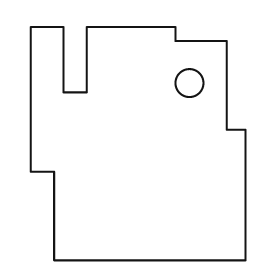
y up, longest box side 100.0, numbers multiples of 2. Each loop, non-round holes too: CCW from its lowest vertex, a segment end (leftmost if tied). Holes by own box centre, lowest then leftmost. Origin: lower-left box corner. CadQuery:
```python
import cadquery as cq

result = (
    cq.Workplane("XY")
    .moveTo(10.0, 0.0)
    .lineTo(92.0, 0.0)
    .lineTo(92.0, 56.0)
    .lineTo(84.0, 56.0)
    .lineTo(84.0, 94.0)
    .lineTo(62.0, 94.0)
    .lineTo(62.0, 100.0)
    .lineTo(24.0, 100.0)
    .lineTo(24.0, 72.0)
    .lineTo(14.0, 72.0)
    .lineTo(14.0, 100.0)
    .lineTo(0.0, 100.0)
    .lineTo(0.0, 38.0)
    .lineTo(10.0, 38.0)
    .close()
    .moveTo(68.0, 76.0)
    .circle(6.0)
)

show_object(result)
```